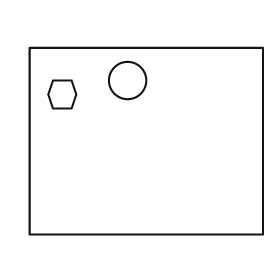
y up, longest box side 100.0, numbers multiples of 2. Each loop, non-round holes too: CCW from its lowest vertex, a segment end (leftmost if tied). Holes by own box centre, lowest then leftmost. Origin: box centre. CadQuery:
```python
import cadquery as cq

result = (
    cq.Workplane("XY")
    .moveTo(-50.0, -40.0)
    .lineTo(50.0, -40.0)
    .lineTo(50.0, 40.0)
    .lineTo(-50.0, 40.0)
    .close()
    .moveTo(-40.0, 14.0)
    .lineTo(-32.0, 14.0)
    .lineTo(-30.0, 20.0)
    .lineTo(-32.0, 26.0)
    .lineTo(-40.0, 26.0)
    .lineTo(-42.0, 20.0)
    .close()
    .moveTo(-8.0, 26.0)
    .circle(8.0)
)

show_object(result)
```